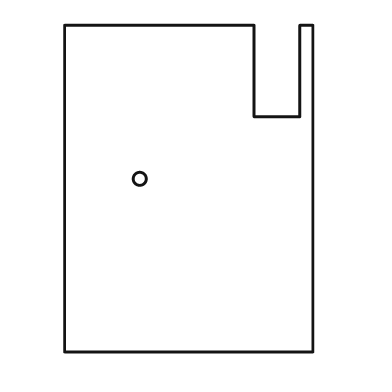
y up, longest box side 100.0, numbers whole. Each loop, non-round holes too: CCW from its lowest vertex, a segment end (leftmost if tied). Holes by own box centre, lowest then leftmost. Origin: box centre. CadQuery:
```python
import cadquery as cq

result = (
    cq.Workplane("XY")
    .moveTo(-38.0, -50.0)
    .lineTo(38.0, -50.0)
    .lineTo(38.0, 50.0)
    .lineTo(34.0, 50.0)
    .lineTo(34.0, 22.0)
    .lineTo(20.0, 22.0)
    .lineTo(20.0, 50.0)
    .lineTo(-38.0, 50.0)
    .close()
    .moveTo(-15.0, 3.0)
    .circle(2.0)
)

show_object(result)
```